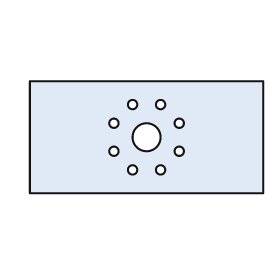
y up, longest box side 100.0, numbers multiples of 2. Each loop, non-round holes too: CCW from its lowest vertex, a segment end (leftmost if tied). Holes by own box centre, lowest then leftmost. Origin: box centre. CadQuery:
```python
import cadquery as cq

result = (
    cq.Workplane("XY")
    .moveTo(-50.0, -24.0)
    .lineTo(50.0, -24.0)
    .lineTo(50.0, 24.0)
    .lineTo(-50.0, 24.0)
    .close()
    .moveTo(-6.0, -14.0)
    .circle(2.0)
    .moveTo(6.0, -14.0)
    .circle(2.0)
    .moveTo(-14.0, -6.0)
    .circle(2.0)
    .moveTo(14.0, -6.0)
    .circle(2.0)
    .moveTo(0.0, 0.0)
    .circle(6.0)
    .moveTo(-14.0, 6.0)
    .circle(2.0)
    .moveTo(14.0, 6.0)
    .circle(2.0)
    .moveTo(-6.0, 14.0)
    .circle(2.0)
    .moveTo(6.0, 14.0)
    .circle(2.0)
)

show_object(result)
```